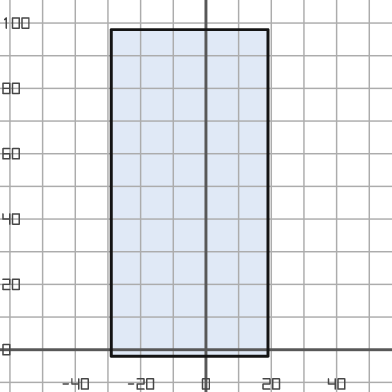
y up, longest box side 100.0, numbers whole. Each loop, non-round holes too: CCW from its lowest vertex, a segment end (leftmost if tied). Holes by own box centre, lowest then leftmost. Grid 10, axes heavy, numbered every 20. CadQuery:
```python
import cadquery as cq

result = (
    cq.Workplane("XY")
    .moveTo(-29.0, -2.0)
    .lineTo(19.0, -2.0)
    .lineTo(19.0, 98.0)
    .lineTo(-29.0, 98.0)
    .close()
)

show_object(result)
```